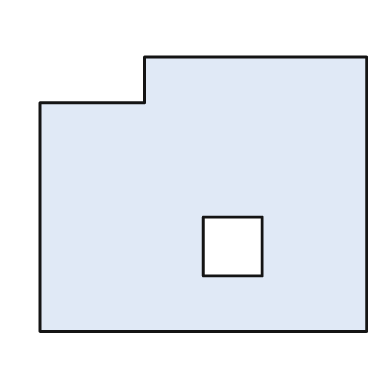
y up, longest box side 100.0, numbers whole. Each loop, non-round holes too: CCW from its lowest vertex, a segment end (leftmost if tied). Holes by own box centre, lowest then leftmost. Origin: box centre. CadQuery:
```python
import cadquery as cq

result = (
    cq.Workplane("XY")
    .moveTo(-50.0, -42.0)
    .lineTo(50.0, -42.0)
    .lineTo(50.0, 42.0)
    .lineTo(-18.0, 42.0)
    .lineTo(-18.0, 28.0)
    .lineTo(-50.0, 28.0)
    .close()
    .moveTo(0.0, -25.0)
    .lineTo(18.0, -25.0)
    .lineTo(18.0, -7.0)
    .lineTo(0.0, -7.0)
    .close()
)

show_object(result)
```